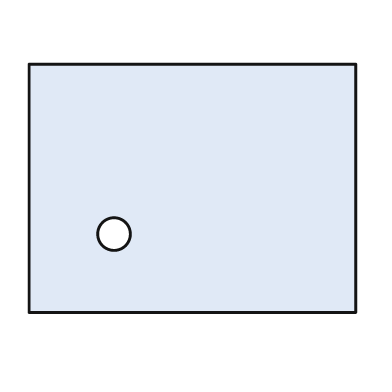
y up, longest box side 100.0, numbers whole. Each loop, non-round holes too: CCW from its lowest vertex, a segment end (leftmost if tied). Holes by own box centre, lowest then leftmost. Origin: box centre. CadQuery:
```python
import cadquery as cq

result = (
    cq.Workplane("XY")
    .moveTo(-50.0, -38.0)
    .lineTo(50.0, -38.0)
    .lineTo(50.0, 38.0)
    .lineTo(-50.0, 38.0)
    .close()
    .moveTo(-24.0, -14.0)
    .circle(5.0)
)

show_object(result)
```